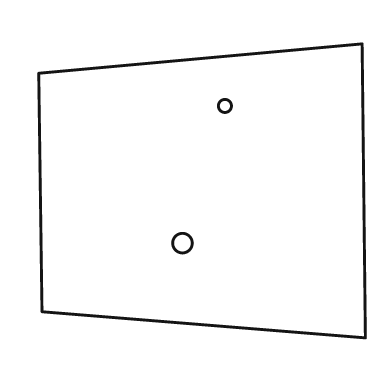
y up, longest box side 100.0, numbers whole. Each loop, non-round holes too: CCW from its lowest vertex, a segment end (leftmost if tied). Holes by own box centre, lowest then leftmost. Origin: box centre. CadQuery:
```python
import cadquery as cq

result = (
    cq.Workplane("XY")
    .moveTo(50.0, -45.0)
    .lineTo(49.0, 45.0)
    .lineTo(-50.0, 36.0)
    .lineTo(-49.0, -37.0)
    .close()
    .moveTo(-6.0, -16.0)
    .circle(3.0)
    .moveTo(7.0, 26.0)
    .circle(2.0)
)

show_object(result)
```